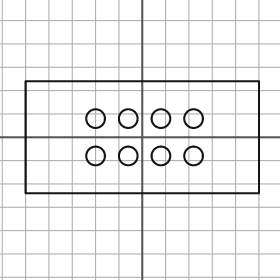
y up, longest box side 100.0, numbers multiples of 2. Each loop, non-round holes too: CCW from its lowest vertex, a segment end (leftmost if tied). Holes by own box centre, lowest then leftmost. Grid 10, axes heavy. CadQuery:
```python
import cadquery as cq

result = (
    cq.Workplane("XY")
    .moveTo(-50.0, -24.0)
    .lineTo(50.0, -24.0)
    .lineTo(50.0, 24.0)
    .lineTo(-50.0, 24.0)
    .close()
    .moveTo(-20.0, -8.0)
    .circle(4.0)
    .moveTo(-6.0, -8.0)
    .circle(4.0)
    .moveTo(8.0, -8.0)
    .circle(4.0)
    .moveTo(22.0, -8.0)
    .circle(4.0)
    .moveTo(-20.0, 8.0)
    .circle(4.0)
    .moveTo(-6.0, 8.0)
    .circle(4.0)
    .moveTo(8.0, 8.0)
    .circle(4.0)
    .moveTo(22.0, 8.0)
    .circle(4.0)
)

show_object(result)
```